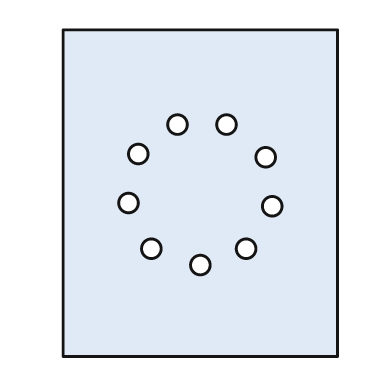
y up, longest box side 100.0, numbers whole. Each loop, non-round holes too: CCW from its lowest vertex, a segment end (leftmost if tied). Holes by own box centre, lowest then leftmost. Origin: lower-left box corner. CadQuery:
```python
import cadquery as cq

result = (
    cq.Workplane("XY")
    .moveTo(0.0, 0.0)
    .lineTo(84.0, 0.0)
    .lineTo(84.0, 100.0)
    .lineTo(0.0, 100.0)
    .close()
    .moveTo(42.0, 28.0)
    .circle(3.0)
    .moveTo(27.0, 33.0)
    .circle(3.0)
    .moveTo(56.0, 33.0)
    .circle(3.0)
    .moveTo(64.0, 46.0)
    .circle(3.0)
    .moveTo(20.0, 47.0)
    .circle(3.0)
    .moveTo(62.0, 61.0)
    .circle(3.0)
    .moveTo(23.0, 62.0)
    .circle(3.0)
    .moveTo(35.0, 71.0)
    .circle(3.0)
    .moveTo(50.0, 71.0)
    .circle(3.0)
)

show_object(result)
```